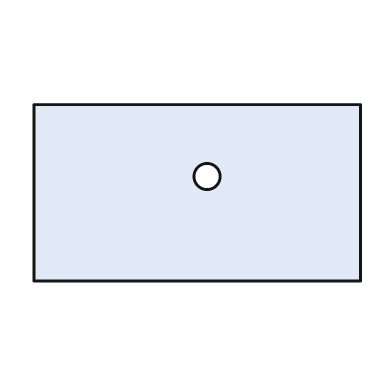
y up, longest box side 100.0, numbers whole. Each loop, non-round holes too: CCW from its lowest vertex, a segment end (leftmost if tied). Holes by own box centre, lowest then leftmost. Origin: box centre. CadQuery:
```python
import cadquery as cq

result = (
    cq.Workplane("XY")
    .moveTo(-50.0, -27.0)
    .lineTo(50.0, -27.0)
    .lineTo(50.0, 27.0)
    .lineTo(-50.0, 27.0)
    .close()
    .moveTo(3.0, 5.0)
    .circle(4.0)
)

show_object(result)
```